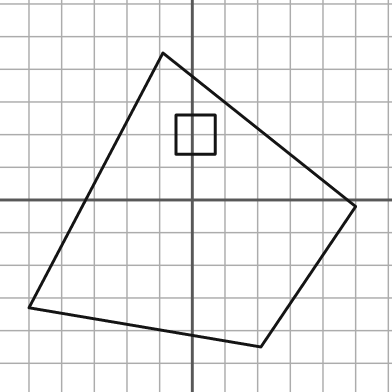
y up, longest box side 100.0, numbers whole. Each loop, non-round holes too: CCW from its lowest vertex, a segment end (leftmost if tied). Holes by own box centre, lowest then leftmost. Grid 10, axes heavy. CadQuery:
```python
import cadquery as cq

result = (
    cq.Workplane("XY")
    .moveTo(21.0, -45.0)
    .lineTo(50.0, -2.0)
    .lineTo(-9.0, 45.0)
    .lineTo(-50.0, -33.0)
    .close()
    .moveTo(-5.0, 14.0)
    .lineTo(7.0, 14.0)
    .lineTo(7.0, 26.0)
    .lineTo(-5.0, 26.0)
    .close()
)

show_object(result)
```